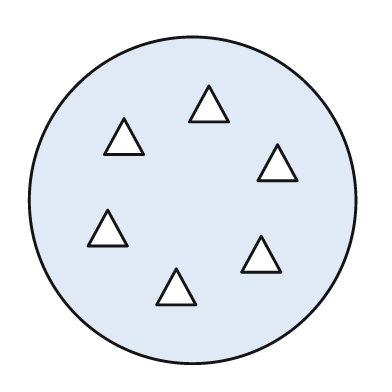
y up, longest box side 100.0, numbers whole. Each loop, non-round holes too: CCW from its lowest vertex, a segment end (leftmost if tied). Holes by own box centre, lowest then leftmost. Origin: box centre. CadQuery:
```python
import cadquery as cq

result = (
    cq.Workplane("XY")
    .moveTo(0.0, 0.0)
    .circle(50.0)
    .moveTo(-11.0, -32.0)
    .lineTo(1.0, -32.0)
    .lineTo(-5.0, -21.0)
    .close()
    .moveTo(15.0, -22.0)
    .lineTo(27.0, -22.0)
    .lineTo(21.0, -11.0)
    .close()
    .moveTo(-32.0, -14.0)
    .lineTo(-20.0, -14.0)
    .lineTo(-26.0, -3.0)
    .close()
    .moveTo(20.0, 6.0)
    .lineTo(32.0, 6.0)
    .lineTo(26.0, 17.0)
    .close()
    .moveTo(-27.0, 14.0)
    .lineTo(-15.0, 14.0)
    .lineTo(-21.0, 25.0)
    .close()
    .moveTo(-1.0, 24.0)
    .lineTo(11.0, 24.0)
    .lineTo(5.0, 35.0)
    .close()
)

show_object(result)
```